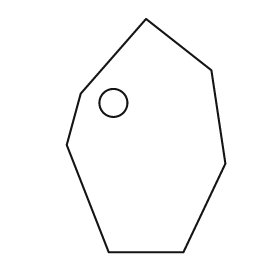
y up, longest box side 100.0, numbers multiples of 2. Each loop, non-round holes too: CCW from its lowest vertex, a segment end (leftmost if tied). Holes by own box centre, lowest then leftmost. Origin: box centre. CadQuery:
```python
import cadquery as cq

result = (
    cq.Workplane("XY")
    .moveTo(-16.0, -50.0)
    .lineTo(16.0, -50.0)
    .lineTo(34.0, -12.0)
    .lineTo(28.0, 28.0)
    .lineTo(0.0, 50.0)
    .lineTo(-28.0, 18.0)
    .lineTo(-34.0, -4.0)
    .close()
    .moveTo(-14.0, 14.0)
    .circle(6.0)
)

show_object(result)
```